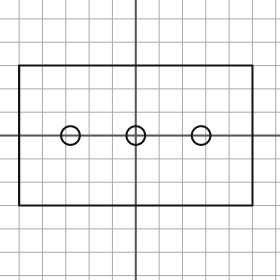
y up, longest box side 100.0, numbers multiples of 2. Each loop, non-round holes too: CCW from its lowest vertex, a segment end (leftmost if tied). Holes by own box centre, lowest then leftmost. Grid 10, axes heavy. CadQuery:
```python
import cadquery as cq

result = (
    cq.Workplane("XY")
    .moveTo(-50.0, -30.0)
    .lineTo(50.0, -30.0)
    .lineTo(50.0, 30.0)
    .lineTo(-50.0, 30.0)
    .close()
    .moveTo(-28.0, 0.0)
    .circle(4.0)
    .moveTo(0.0, 0.0)
    .circle(4.0)
    .moveTo(28.0, 0.0)
    .circle(4.0)
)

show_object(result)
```